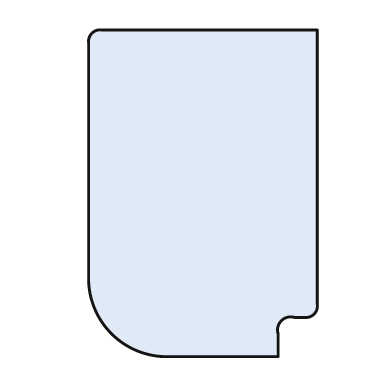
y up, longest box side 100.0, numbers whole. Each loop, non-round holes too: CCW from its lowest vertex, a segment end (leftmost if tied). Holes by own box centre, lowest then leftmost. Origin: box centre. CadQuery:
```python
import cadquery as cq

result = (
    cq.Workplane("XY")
    .moveTo(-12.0, -50.0)
    .lineTo(23.0, -50.0)
    .lineTo(23.0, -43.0)
    .threePointArc((24.0, -39.0), (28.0, -38.0))
    .lineTo(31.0, -38.0)
    .threePointArc((34.0, -37.0), (35.0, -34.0))
    .lineTo(35.0, 50.0)
    .lineTo(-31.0, 50.0)
    .threePointArc((-34.0, 49.0), (-35.0, 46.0))
    .lineTo(-35.0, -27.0)
    .threePointArc((-28.0, -43.0), (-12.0, -50.0))
    .close()
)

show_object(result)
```